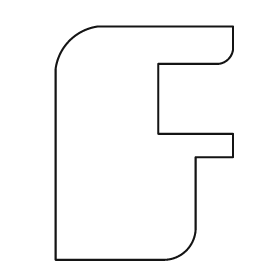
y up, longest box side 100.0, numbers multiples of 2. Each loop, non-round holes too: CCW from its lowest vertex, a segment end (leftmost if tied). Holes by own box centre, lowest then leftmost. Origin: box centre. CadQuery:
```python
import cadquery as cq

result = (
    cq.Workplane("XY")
    .moveTo(-38.0, -50.0)
    .lineTo(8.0, -50.0)
    .threePointArc((18.0, -46.0), (22.0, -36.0))
    .lineTo(22.0, -6.0)
    .lineTo(38.0, -6.0)
    .lineTo(38.0, 4.0)
    .lineTo(6.0, 4.0)
    .lineTo(6.0, 34.0)
    .lineTo(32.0, 34.0)
    .threePointArc((36.0, 36.0), (38.0, 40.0))
    .lineTo(38.0, 50.0)
    .lineTo(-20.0, 50.0)
    .threePointArc((-32.0, 44.0), (-38.0, 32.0))
    .close()
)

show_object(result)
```